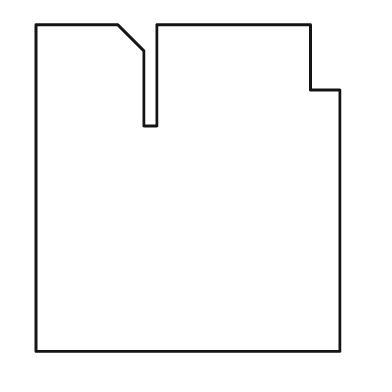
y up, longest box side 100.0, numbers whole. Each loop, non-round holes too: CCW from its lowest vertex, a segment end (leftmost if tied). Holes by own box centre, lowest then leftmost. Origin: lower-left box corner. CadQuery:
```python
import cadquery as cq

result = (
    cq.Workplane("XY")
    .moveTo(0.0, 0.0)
    .lineTo(93.0, 0.0)
    .lineTo(93.0, 80.0)
    .lineTo(84.0, 80.0)
    .lineTo(84.0, 100.0)
    .lineTo(37.0, 100.0)
    .lineTo(37.0, 69.0)
    .lineTo(33.0, 69.0)
    .lineTo(33.0, 92.0)
    .lineTo(25.0, 100.0)
    .lineTo(0.0, 100.0)
    .close()
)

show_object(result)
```